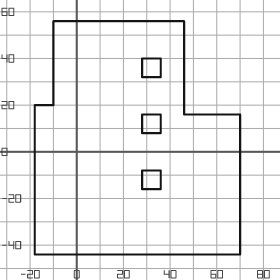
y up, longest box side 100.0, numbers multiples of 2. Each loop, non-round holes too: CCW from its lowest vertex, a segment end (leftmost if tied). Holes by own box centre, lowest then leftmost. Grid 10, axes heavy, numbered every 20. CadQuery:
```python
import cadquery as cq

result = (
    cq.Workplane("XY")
    .moveTo(-18.0, -44.0)
    .lineTo(70.0, -44.0)
    .lineTo(70.0, 16.0)
    .lineTo(46.0, 16.0)
    .lineTo(46.0, 56.0)
    .lineTo(-10.0, 56.0)
    .lineTo(-10.0, 20.0)
    .lineTo(-18.0, 20.0)
    .close()
    .moveTo(28.0, -16.0)
    .lineTo(36.0, -16.0)
    .lineTo(36.0, -8.0)
    .lineTo(28.0, -8.0)
    .close()
    .moveTo(28.0, 8.0)
    .lineTo(36.0, 8.0)
    .lineTo(36.0, 16.0)
    .lineTo(28.0, 16.0)
    .close()
    .moveTo(28.0, 32.0)
    .lineTo(36.0, 32.0)
    .lineTo(36.0, 40.0)
    .lineTo(28.0, 40.0)
    .close()
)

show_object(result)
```